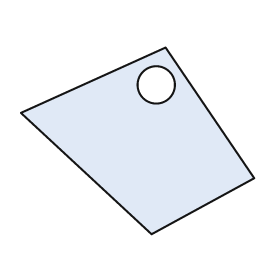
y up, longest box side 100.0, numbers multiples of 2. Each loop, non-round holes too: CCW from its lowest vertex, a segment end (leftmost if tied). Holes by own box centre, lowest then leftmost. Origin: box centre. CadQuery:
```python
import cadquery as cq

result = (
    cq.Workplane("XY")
    .moveTo(6.0, -40.0)
    .lineTo(50.0, -16.0)
    .lineTo(12.0, 40.0)
    .lineTo(-50.0, 12.0)
    .close()
    .moveTo(8.0, 24.0)
    .circle(8.0)
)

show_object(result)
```